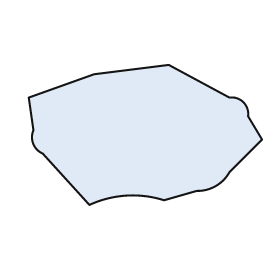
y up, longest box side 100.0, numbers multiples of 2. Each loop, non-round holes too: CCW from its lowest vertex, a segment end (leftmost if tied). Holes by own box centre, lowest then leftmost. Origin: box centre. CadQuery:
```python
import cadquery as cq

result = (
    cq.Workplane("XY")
    .moveTo(-24.0, -30.0)
    .threePointArc((-8.0, -26.0), (8.0, -28.0))
    .lineTo(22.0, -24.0)
    .threePointArc((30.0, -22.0), (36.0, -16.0))
    .lineTo(50.0, -2.0)
    .lineTo(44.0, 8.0)
    .threePointArc((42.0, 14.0), (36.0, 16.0))
    .lineTo(10.0, 30.0)
    .lineTo(-22.0, 26.0)
    .lineTo(-50.0, 16.0)
    .lineTo(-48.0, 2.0)
    .threePointArc((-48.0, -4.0), (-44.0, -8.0))
    .close()
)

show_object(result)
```